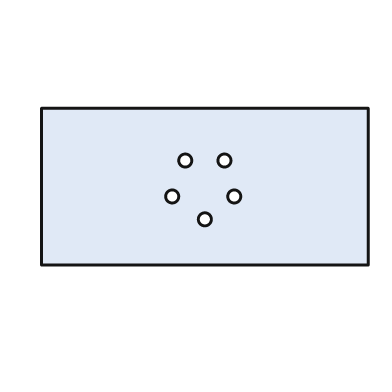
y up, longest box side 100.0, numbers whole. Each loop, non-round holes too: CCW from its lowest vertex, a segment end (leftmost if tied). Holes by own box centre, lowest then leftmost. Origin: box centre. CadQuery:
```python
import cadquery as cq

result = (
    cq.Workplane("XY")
    .moveTo(-50.0, -24.0)
    .lineTo(50.0, -24.0)
    .lineTo(50.0, 24.0)
    .lineTo(-50.0, 24.0)
    .close()
    .moveTo(0.0, -10.0)
    .circle(2.0)
    .moveTo(-10.0, -3.0)
    .circle(2.0)
    .moveTo(9.0, -3.0)
    .circle(2.0)
    .moveTo(-6.0, 8.0)
    .circle(2.0)
    .moveTo(6.0, 8.0)
    .circle(2.0)
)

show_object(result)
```